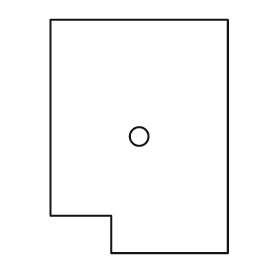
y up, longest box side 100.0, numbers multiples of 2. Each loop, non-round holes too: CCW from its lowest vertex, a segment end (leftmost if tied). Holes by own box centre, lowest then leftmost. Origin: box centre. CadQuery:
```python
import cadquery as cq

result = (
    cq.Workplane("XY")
    .moveTo(-12.0, -50.0)
    .lineTo(38.0, -50.0)
    .lineTo(38.0, 50.0)
    .lineTo(-38.0, 50.0)
    .lineTo(-38.0, -34.0)
    .lineTo(-12.0, -34.0)
    .close()
    .moveTo(0.0, 0.0)
    .circle(4.0)
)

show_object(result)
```